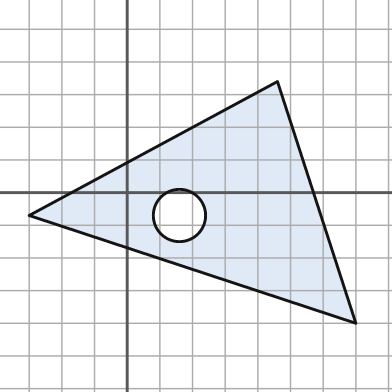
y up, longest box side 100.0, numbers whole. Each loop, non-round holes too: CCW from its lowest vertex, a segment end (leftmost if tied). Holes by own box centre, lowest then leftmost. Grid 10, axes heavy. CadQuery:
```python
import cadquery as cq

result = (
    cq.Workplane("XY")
    .moveTo(70.0, -40.0)
    .lineTo(46.0, 34.0)
    .lineTo(-30.0, -7.0)
    .close()
    .moveTo(16.0, -7.0)
    .circle(8.0)
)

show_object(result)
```